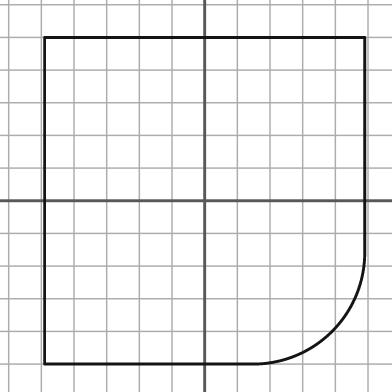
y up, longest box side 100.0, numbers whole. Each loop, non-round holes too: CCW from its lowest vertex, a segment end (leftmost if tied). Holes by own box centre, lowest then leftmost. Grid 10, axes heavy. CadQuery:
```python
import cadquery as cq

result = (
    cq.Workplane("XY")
    .moveTo(-49.0, -50.0)
    .lineTo(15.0, -50.0)
    .threePointArc((39.0, -40.0), (49.0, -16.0))
    .lineTo(49.0, 50.0)
    .lineTo(-49.0, 50.0)
    .close()
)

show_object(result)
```